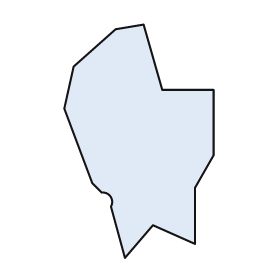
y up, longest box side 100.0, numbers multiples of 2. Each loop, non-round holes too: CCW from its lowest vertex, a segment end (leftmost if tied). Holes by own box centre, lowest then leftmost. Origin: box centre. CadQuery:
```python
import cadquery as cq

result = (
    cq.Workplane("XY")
    .moveTo(-6.0, -50.0)
    .lineTo(6.0, -36.0)
    .lineTo(24.0, -44.0)
    .lineTo(24.0, -20.0)
    .lineTo(32.0, -6.0)
    .lineTo(32.0, 22.0)
    .lineTo(10.0, 22.0)
    .lineTo(2.0, 50.0)
    .lineTo(-10.0, 48.0)
    .lineTo(-28.0, 32.0)
    .lineTo(-32.0, 14.0)
    .lineTo(-20.0, -18.0)
    .lineTo(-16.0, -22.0)
    .threePointArc((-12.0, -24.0), (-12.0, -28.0))
    .close()
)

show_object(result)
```